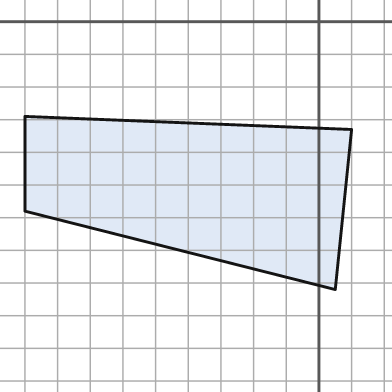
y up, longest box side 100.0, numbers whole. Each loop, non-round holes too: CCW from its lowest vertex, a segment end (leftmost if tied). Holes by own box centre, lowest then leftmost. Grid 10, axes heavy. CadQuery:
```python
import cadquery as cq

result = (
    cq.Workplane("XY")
    .moveTo(5.0, -82.0)
    .lineTo(10.0, -33.0)
    .lineTo(-90.0, -29.0)
    .lineTo(-90.0, -58.0)
    .close()
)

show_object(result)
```